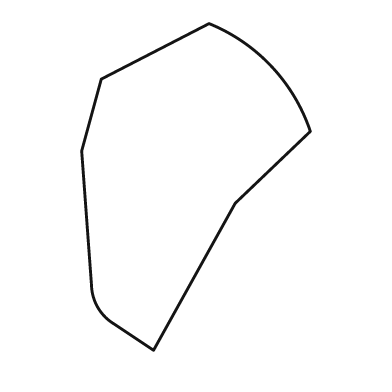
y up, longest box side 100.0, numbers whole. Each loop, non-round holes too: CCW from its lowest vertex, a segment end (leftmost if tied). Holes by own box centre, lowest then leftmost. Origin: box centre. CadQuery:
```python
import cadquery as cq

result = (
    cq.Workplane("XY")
    .moveTo(-13.0, -50.0)
    .lineTo(12.0, -5.0)
    .lineTo(35.0, 17.0)
    .threePointArc((23.0, 37.0), (4.0, 50.0))
    .lineTo(-29.0, 33.0)
    .lineTo(-35.0, 11.0)
    .lineTo(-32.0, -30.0)
    .threePointArc((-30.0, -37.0), (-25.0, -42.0))
    .close()
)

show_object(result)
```